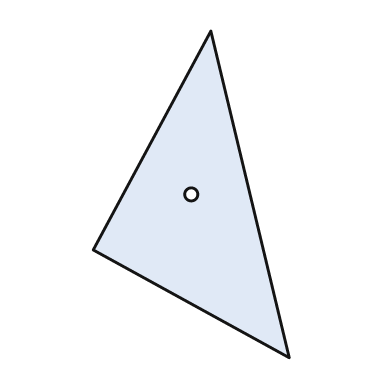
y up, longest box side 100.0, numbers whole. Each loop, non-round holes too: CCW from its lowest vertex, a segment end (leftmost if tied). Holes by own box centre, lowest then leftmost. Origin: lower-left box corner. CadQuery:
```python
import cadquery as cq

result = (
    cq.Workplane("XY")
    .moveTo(60.0, 0.0)
    .lineTo(36.0, 100.0)
    .lineTo(0.0, 33.0)
    .close()
    .moveTo(30.0, 50.0)
    .circle(2.0)
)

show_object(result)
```